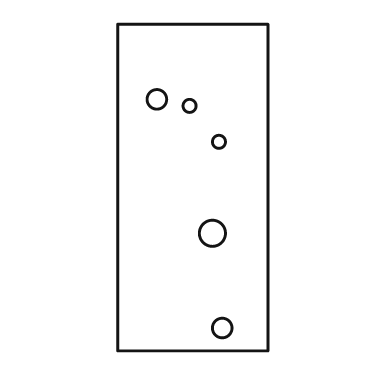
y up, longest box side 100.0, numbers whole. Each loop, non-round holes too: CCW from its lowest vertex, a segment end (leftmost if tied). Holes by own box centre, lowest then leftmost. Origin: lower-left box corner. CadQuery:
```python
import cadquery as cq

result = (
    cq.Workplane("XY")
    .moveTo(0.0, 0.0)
    .lineTo(46.0, 0.0)
    .lineTo(46.0, 100.0)
    .lineTo(0.0, 100.0)
    .close()
    .moveTo(32.0, 7.0)
    .circle(3.0)
    .moveTo(29.0, 36.0)
    .circle(4.0)
    .moveTo(31.0, 64.0)
    .circle(2.0)
    .moveTo(22.0, 75.0)
    .circle(2.0)
    .moveTo(12.0, 77.0)
    .circle(3.0)
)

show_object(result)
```